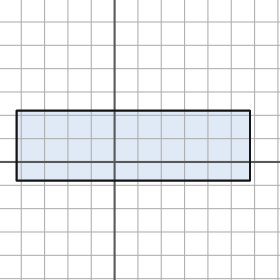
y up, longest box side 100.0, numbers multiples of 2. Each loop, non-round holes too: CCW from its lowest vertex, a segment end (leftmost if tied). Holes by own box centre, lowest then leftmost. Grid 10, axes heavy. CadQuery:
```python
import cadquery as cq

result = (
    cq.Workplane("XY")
    .moveTo(-42.0, -8.0)
    .lineTo(58.0, -8.0)
    .lineTo(58.0, 22.0)
    .lineTo(-42.0, 22.0)
    .close()
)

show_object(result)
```